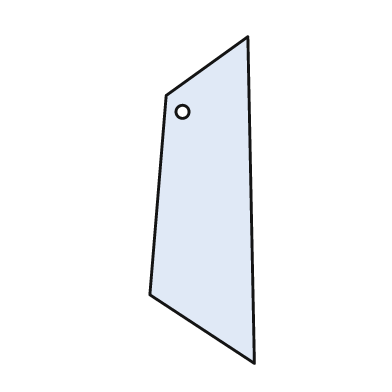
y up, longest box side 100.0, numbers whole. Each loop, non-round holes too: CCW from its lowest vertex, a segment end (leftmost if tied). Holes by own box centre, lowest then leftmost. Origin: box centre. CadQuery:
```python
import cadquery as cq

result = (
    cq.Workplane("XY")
    .moveTo(16.0, -50.0)
    .lineTo(14.0, 50.0)
    .lineTo(-11.0, 32.0)
    .lineTo(-16.0, -29.0)
    .close()
    .moveTo(-6.0, 27.0)
    .circle(2.0)
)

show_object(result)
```